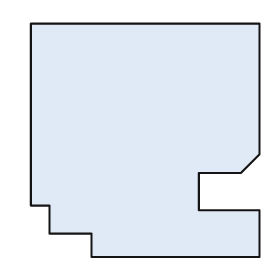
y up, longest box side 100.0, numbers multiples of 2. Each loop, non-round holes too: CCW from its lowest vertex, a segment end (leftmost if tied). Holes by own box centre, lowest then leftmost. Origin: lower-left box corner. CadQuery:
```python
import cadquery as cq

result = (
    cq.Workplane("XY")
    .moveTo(26.0, 0.0)
    .lineTo(98.0, 0.0)
    .lineTo(98.0, 20.0)
    .lineTo(72.0, 20.0)
    .lineTo(72.0, 36.0)
    .lineTo(90.0, 36.0)
    .lineTo(98.0, 44.0)
    .lineTo(98.0, 100.0)
    .lineTo(0.0, 100.0)
    .lineTo(0.0, 22.0)
    .lineTo(8.0, 22.0)
    .lineTo(8.0, 10.0)
    .lineTo(26.0, 10.0)
    .close()
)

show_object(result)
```